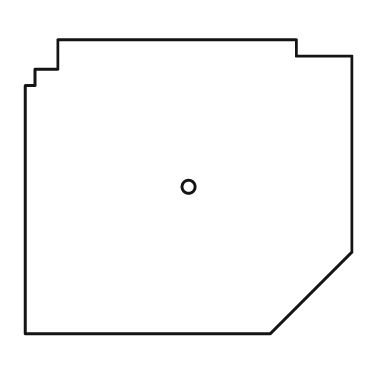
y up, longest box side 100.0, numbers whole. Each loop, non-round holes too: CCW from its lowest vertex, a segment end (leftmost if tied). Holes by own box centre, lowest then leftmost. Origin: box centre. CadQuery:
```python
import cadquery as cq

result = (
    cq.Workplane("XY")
    .moveTo(-50.0, -45.0)
    .lineTo(25.0, -45.0)
    .lineTo(50.0, -20.0)
    .lineTo(50.0, 40.0)
    .lineTo(33.0, 40.0)
    .lineTo(33.0, 45.0)
    .lineTo(-40.0, 45.0)
    .lineTo(-40.0, 36.0)
    .lineTo(-47.0, 36.0)
    .lineTo(-47.0, 31.0)
    .lineTo(-50.0, 31.0)
    .close()
    .moveTo(0.0, 0.0)
    .circle(2.0)
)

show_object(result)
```